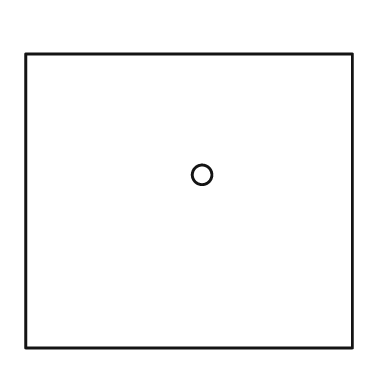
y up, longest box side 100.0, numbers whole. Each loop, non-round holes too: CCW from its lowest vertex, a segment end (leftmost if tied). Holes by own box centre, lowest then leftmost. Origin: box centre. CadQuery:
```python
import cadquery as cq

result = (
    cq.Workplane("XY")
    .moveTo(-50.0, -45.0)
    .lineTo(50.0, -45.0)
    .lineTo(50.0, 45.0)
    .lineTo(-50.0, 45.0)
    .close()
    .moveTo(4.0, 8.0)
    .circle(3.0)
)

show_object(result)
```